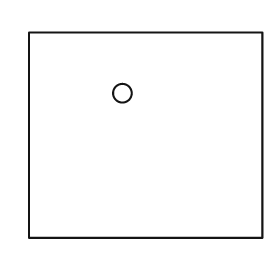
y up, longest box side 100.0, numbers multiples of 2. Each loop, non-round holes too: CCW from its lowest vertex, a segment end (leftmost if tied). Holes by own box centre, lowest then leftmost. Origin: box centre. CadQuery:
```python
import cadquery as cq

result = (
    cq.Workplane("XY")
    .moveTo(-50.0, -44.0)
    .lineTo(50.0, -44.0)
    .lineTo(50.0, 44.0)
    .lineTo(-50.0, 44.0)
    .close()
    .moveTo(-10.0, 18.0)
    .circle(4.0)
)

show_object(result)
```